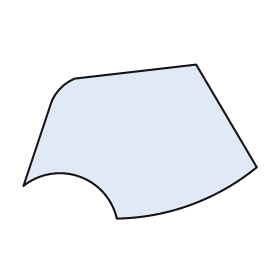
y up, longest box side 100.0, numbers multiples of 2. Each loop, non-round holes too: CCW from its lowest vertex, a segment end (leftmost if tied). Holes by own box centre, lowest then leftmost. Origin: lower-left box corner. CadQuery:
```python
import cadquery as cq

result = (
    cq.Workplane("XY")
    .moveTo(40.0, 0.0)
    .threePointArc((72.0, 6.0), (100.0, 22.0))
    .lineTo(74.0, 66.0)
    .lineTo(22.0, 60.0)
    .threePointArc((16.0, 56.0), (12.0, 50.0))
    .lineTo(0.0, 14.0)
    .threePointArc((24.0, 18.0), (40.0, 0.0))
    .close()
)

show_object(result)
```